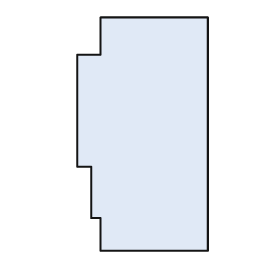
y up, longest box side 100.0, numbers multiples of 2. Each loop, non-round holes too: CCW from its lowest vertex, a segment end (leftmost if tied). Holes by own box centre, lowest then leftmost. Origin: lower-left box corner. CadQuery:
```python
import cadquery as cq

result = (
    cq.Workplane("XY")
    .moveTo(10.0, 0.0)
    .lineTo(56.0, 0.0)
    .lineTo(56.0, 100.0)
    .lineTo(10.0, 100.0)
    .lineTo(10.0, 84.0)
    .lineTo(0.0, 84.0)
    .lineTo(0.0, 36.0)
    .lineTo(6.0, 36.0)
    .lineTo(6.0, 14.0)
    .lineTo(10.0, 14.0)
    .close()
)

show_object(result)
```